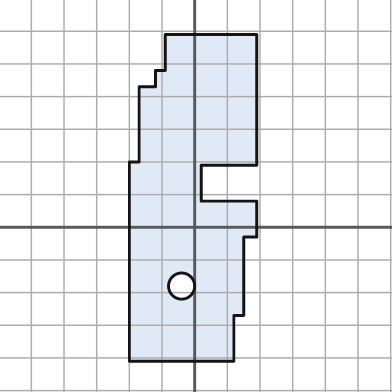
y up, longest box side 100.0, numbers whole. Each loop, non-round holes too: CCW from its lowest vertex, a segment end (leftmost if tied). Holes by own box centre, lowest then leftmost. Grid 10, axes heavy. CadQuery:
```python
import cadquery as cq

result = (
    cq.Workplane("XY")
    .moveTo(-20.0, -41.0)
    .lineTo(12.0, -41.0)
    .lineTo(12.0, -27.0)
    .lineTo(15.0, -27.0)
    .lineTo(15.0, -3.0)
    .lineTo(19.0, -3.0)
    .lineTo(19.0, 8.0)
    .lineTo(2.0, 8.0)
    .lineTo(2.0, 19.0)
    .lineTo(19.0, 19.0)
    .lineTo(19.0, 59.0)
    .lineTo(-9.0, 59.0)
    .lineTo(-9.0, 48.0)
    .lineTo(-12.0, 48.0)
    .lineTo(-12.0, 43.0)
    .lineTo(-17.0, 43.0)
    .lineTo(-17.0, 20.0)
    .lineTo(-20.0, 20.0)
    .close()
    .moveTo(-4.0, -18.0)
    .circle(4.0)
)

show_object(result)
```